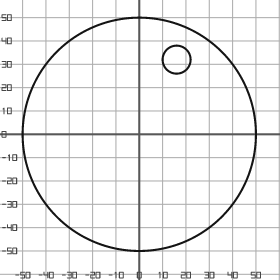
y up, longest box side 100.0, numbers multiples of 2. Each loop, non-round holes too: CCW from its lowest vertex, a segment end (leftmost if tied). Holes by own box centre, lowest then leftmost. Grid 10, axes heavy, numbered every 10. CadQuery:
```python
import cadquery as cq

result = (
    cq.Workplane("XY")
    .moveTo(0.0, 0.0)
    .circle(50.0)
    .moveTo(16.0, 32.0)
    .circle(6.0)
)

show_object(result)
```